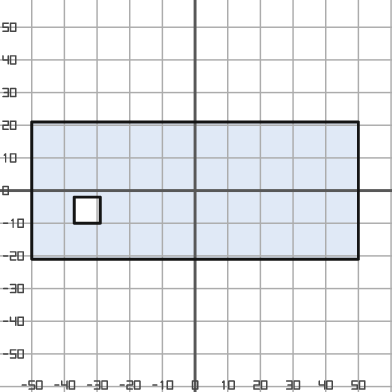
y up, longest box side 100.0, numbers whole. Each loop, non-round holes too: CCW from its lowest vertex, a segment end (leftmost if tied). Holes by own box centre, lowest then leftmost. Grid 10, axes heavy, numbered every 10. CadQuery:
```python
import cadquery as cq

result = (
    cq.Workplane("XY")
    .moveTo(-50.0, -21.0)
    .lineTo(50.0, -21.0)
    .lineTo(50.0, 21.0)
    .lineTo(-50.0, 21.0)
    .close()
    .moveTo(-37.0, -10.0)
    .lineTo(-29.0, -10.0)
    .lineTo(-29.0, -2.0)
    .lineTo(-37.0, -2.0)
    .close()
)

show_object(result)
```